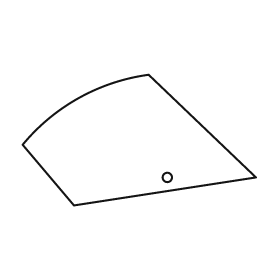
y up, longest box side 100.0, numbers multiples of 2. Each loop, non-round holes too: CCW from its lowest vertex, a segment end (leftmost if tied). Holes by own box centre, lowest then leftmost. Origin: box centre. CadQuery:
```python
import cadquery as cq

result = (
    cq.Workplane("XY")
    .moveTo(-28.0, -28.0)
    .lineTo(50.0, -16.0)
    .lineTo(4.0, 28.0)
    .threePointArc((-26.0, 18.0), (-50.0, -2.0))
    .close()
    .moveTo(12.0, -16.0)
    .circle(2.0)
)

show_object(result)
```